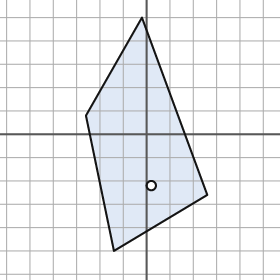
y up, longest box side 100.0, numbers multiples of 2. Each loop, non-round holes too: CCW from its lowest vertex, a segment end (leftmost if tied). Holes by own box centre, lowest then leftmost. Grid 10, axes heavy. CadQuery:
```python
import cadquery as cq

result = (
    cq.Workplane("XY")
    .moveTo(-14.0, -50.0)
    .lineTo(26.0, -26.0)
    .lineTo(-2.0, 50.0)
    .lineTo(-26.0, 8.0)
    .close()
    .moveTo(2.0, -22.0)
    .circle(2.0)
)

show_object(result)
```